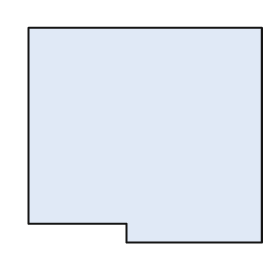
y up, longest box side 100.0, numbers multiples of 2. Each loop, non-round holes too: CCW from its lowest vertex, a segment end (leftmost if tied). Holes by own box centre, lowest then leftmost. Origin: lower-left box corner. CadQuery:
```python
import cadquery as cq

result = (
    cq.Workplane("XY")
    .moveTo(42.0, 0.0)
    .lineTo(100.0, 0.0)
    .lineTo(100.0, 92.0)
    .lineTo(0.0, 92.0)
    .lineTo(0.0, 8.0)
    .lineTo(42.0, 8.0)
    .close()
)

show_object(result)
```